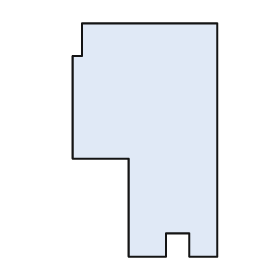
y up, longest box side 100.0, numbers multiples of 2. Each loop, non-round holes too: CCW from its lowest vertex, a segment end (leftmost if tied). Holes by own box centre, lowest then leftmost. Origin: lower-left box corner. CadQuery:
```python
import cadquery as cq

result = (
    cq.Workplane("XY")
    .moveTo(24.0, 0.0)
    .lineTo(40.0, 0.0)
    .lineTo(40.0, 10.0)
    .lineTo(50.0, 10.0)
    .lineTo(50.0, 0.0)
    .lineTo(62.0, 0.0)
    .lineTo(62.0, 100.0)
    .lineTo(4.0, 100.0)
    .lineTo(4.0, 86.0)
    .lineTo(0.0, 86.0)
    .lineTo(0.0, 42.0)
    .lineTo(24.0, 42.0)
    .close()
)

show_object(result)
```